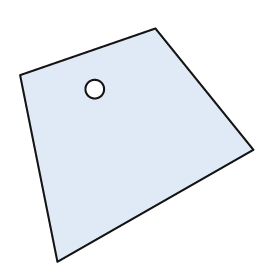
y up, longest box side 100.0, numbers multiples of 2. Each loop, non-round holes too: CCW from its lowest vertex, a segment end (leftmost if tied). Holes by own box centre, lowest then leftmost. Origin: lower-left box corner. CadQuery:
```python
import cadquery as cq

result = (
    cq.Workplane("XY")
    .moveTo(16.0, 0.0)
    .lineTo(100.0, 48.0)
    .lineTo(58.0, 100.0)
    .lineTo(0.0, 80.0)
    .close()
    .moveTo(32.0, 74.0)
    .circle(4.0)
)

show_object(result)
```